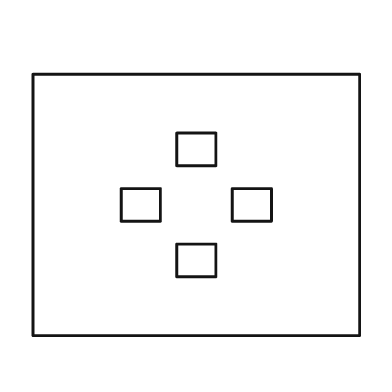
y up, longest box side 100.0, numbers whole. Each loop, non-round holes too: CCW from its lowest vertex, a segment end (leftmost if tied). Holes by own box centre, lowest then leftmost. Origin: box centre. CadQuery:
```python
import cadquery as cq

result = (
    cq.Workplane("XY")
    .moveTo(-50.0, -40.0)
    .lineTo(50.0, -40.0)
    .lineTo(50.0, 40.0)
    .lineTo(-50.0, 40.0)
    .close()
    .moveTo(-6.0, -22.0)
    .lineTo(6.0, -22.0)
    .lineTo(6.0, -12.0)
    .lineTo(-6.0, -12.0)
    .close()
    .moveTo(-23.0, -5.0)
    .lineTo(-11.0, -5.0)
    .lineTo(-11.0, 5.0)
    .lineTo(-23.0, 5.0)
    .close()
    .moveTo(11.0, -5.0)
    .lineTo(23.0, -5.0)
    .lineTo(23.0, 5.0)
    .lineTo(11.0, 5.0)
    .close()
    .moveTo(-6.0, 12.0)
    .lineTo(6.0, 12.0)
    .lineTo(6.0, 22.0)
    .lineTo(-6.0, 22.0)
    .close()
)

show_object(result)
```